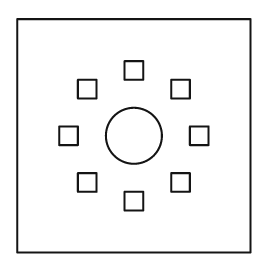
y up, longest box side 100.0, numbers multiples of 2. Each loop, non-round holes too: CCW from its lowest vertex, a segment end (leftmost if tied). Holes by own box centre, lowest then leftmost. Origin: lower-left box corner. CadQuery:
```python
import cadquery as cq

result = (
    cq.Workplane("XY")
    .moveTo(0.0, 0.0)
    .lineTo(100.0, 0.0)
    .lineTo(100.0, 100.0)
    .lineTo(0.0, 100.0)
    .close()
    .moveTo(46.0, 18.0)
    .lineTo(54.0, 18.0)
    .lineTo(54.0, 26.0)
    .lineTo(46.0, 26.0)
    .close()
    .moveTo(26.0, 26.0)
    .lineTo(34.0, 26.0)
    .lineTo(34.0, 34.0)
    .lineTo(26.0, 34.0)
    .close()
    .moveTo(66.0, 26.0)
    .lineTo(74.0, 26.0)
    .lineTo(74.0, 34.0)
    .lineTo(66.0, 34.0)
    .close()
    .moveTo(18.0, 46.0)
    .lineTo(26.0, 46.0)
    .lineTo(26.0, 54.0)
    .lineTo(18.0, 54.0)
    .close()
    .moveTo(50.0, 50.0)
    .circle(12.0)
    .moveTo(74.0, 46.0)
    .lineTo(82.0, 46.0)
    .lineTo(82.0, 54.0)
    .lineTo(74.0, 54.0)
    .close()
    .moveTo(26.0, 66.0)
    .lineTo(34.0, 66.0)
    .lineTo(34.0, 74.0)
    .lineTo(26.0, 74.0)
    .close()
    .moveTo(66.0, 66.0)
    .lineTo(74.0, 66.0)
    .lineTo(74.0, 74.0)
    .lineTo(66.0, 74.0)
    .close()
    .moveTo(46.0, 74.0)
    .lineTo(54.0, 74.0)
    .lineTo(54.0, 82.0)
    .lineTo(46.0, 82.0)
    .close()
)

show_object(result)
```